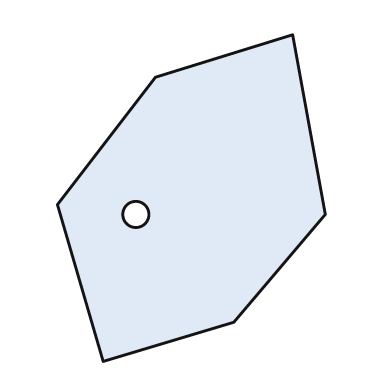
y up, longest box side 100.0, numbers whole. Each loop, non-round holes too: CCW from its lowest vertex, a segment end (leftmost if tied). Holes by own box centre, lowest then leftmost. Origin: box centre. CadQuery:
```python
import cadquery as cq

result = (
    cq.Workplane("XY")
    .moveTo(-27.0, -50.0)
    .lineTo(13.0, -38.0)
    .lineTo(41.0, -5.0)
    .lineTo(31.0, 50.0)
    .lineTo(-11.0, 37.0)
    .lineTo(-41.0, -2.0)
    .close()
    .moveTo(-17.0, -5.0)
    .circle(4.0)
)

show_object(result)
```